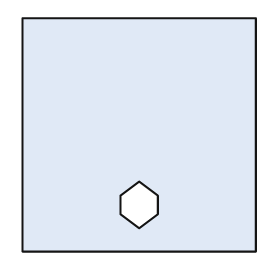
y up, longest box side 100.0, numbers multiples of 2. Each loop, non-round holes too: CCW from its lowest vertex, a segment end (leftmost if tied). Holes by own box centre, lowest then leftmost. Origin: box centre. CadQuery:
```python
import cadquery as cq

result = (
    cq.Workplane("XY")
    .moveTo(-50.0, -50.0)
    .lineTo(50.0, -50.0)
    .lineTo(50.0, 50.0)
    .lineTo(-50.0, 50.0)
    .close()
    .moveTo(0.0, -40.0)
    .lineTo(8.0, -34.0)
    .lineTo(8.0, -26.0)
    .lineTo(0.0, -20.0)
    .lineTo(-8.0, -26.0)
    .lineTo(-8.0, -34.0)
    .close()
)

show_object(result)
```